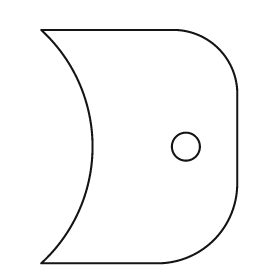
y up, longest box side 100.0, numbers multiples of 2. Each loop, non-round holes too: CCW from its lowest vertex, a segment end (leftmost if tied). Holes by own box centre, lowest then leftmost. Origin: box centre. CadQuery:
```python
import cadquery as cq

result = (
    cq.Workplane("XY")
    .moveTo(-42.0, -50.0)
    .lineTo(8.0, -50.0)
    .threePointArc((32.0, -40.0), (42.0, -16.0))
    .lineTo(42.0, 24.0)
    .threePointArc((34.0, 42.0), (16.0, 50.0))
    .lineTo(-42.0, 50.0)
    .threePointArc((-20.0, 0.0), (-42.0, -50.0))
    .close()
    .moveTo(20.0, 0.0)
    .circle(6.0)
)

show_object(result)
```